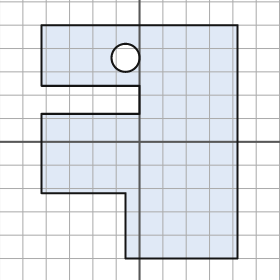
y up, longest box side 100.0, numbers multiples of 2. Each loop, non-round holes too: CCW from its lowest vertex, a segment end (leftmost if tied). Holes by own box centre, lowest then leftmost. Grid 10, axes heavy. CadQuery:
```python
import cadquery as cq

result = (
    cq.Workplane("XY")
    .moveTo(-6.0, -50.0)
    .lineTo(42.0, -50.0)
    .lineTo(42.0, 50.0)
    .lineTo(-42.0, 50.0)
    .lineTo(-42.0, 24.0)
    .lineTo(0.0, 24.0)
    .lineTo(0.0, 12.0)
    .lineTo(-42.0, 12.0)
    .lineTo(-42.0, -22.0)
    .lineTo(-6.0, -22.0)
    .close()
    .moveTo(-6.0, 36.0)
    .circle(6.0)
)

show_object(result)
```